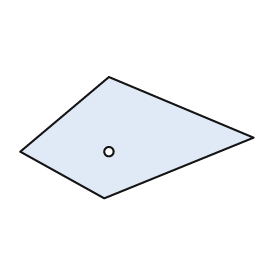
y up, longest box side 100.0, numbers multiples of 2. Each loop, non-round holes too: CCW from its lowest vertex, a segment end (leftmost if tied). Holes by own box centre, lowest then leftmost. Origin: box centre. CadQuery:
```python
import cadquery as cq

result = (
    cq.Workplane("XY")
    .moveTo(-14.0, -26.0)
    .lineTo(50.0, 0.0)
    .lineTo(-12.0, 26.0)
    .lineTo(-50.0, -6.0)
    .close()
    .moveTo(-12.0, -6.0)
    .circle(2.0)
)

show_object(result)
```